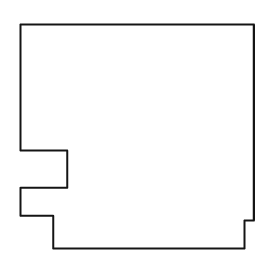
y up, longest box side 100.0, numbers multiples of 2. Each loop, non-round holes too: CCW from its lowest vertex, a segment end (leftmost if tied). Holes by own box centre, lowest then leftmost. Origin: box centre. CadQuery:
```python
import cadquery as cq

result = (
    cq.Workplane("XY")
    .moveTo(-36.0, -48.0)
    .lineTo(46.0, -48.0)
    .lineTo(46.0, -36.0)
    .lineTo(50.0, -36.0)
    .lineTo(50.0, 48.0)
    .lineTo(-50.0, 48.0)
    .lineTo(-50.0, -6.0)
    .lineTo(-30.0, -6.0)
    .lineTo(-30.0, -22.0)
    .lineTo(-50.0, -22.0)
    .lineTo(-50.0, -34.0)
    .lineTo(-36.0, -34.0)
    .close()
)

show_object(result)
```